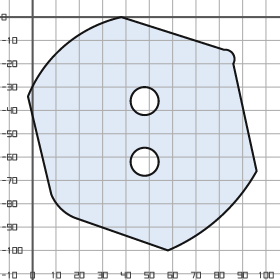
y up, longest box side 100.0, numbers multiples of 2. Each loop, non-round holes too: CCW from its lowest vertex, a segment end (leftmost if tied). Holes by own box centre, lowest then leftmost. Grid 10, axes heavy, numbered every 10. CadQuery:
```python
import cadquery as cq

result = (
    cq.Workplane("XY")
    .moveTo(58.0, -100.0)
    .threePointArc((80.0, -86.0), (96.0, -66.0))
    .lineTo(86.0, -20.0)
    .threePointArc((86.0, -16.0), (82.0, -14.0))
    .lineTo(38.0, 0.0)
    .threePointArc((14.0, -12.0), (-2.0, -34.0))
    .lineTo(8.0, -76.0)
    .threePointArc((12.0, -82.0), (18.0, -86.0))
    .close()
    .moveTo(48.0, -62.0)
    .circle(6.0)
    .moveTo(48.0, -36.0)
    .circle(6.0)
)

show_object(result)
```